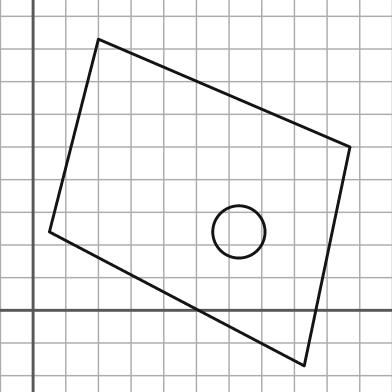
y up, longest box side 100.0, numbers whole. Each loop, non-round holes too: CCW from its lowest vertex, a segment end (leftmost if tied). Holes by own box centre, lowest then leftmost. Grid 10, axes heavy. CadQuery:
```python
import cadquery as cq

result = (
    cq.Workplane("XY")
    .moveTo(83.0, -17.0)
    .lineTo(97.0, 50.0)
    .lineTo(20.0, 83.0)
    .lineTo(5.0, 24.0)
    .close()
    .moveTo(63.0, 24.0)
    .circle(8.0)
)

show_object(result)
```